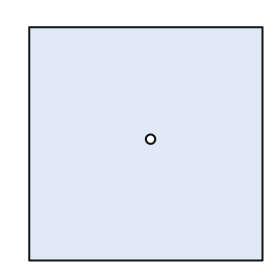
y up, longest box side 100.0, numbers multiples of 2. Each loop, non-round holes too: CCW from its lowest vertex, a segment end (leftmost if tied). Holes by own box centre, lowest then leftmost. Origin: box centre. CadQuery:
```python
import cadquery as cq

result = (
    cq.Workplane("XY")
    .moveTo(-50.0, -50.0)
    .lineTo(50.0, -50.0)
    .lineTo(50.0, 50.0)
    .lineTo(-50.0, 50.0)
    .close()
    .moveTo(2.0, 2.0)
    .circle(2.0)
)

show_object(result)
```